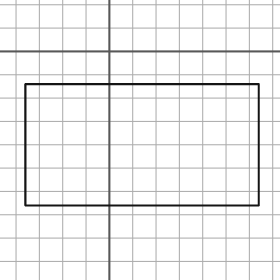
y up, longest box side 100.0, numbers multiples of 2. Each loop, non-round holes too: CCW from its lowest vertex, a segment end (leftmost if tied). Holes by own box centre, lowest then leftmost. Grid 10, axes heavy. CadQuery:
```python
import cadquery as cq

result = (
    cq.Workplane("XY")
    .moveTo(-36.0, -66.0)
    .lineTo(64.0, -66.0)
    .lineTo(64.0, -14.0)
    .lineTo(-36.0, -14.0)
    .close()
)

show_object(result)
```